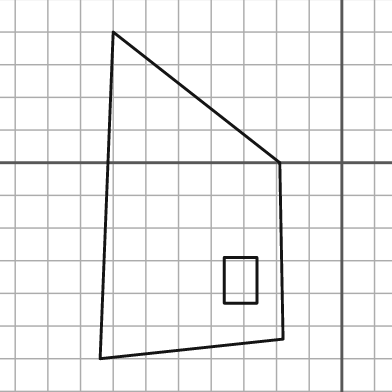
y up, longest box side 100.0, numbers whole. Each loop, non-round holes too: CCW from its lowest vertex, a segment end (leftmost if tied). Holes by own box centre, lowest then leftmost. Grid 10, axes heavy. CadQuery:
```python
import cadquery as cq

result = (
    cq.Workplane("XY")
    .moveTo(-74.0, -60.0)
    .lineTo(-18.0, -54.0)
    .lineTo(-19.0, 0.0)
    .lineTo(-70.0, 40.0)
    .close()
    .moveTo(-36.0, -43.0)
    .lineTo(-26.0, -43.0)
    .lineTo(-26.0, -29.0)
    .lineTo(-36.0, -29.0)
    .close()
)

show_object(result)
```